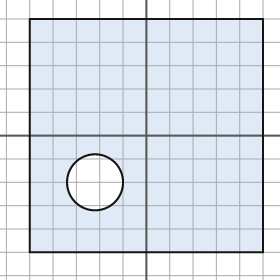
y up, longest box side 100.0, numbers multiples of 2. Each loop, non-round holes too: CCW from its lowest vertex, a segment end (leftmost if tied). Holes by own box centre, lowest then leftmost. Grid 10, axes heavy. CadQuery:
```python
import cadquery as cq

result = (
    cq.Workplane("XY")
    .moveTo(-50.0, -50.0)
    .lineTo(50.0, -50.0)
    .lineTo(50.0, 50.0)
    .lineTo(-50.0, 50.0)
    .close()
    .moveTo(-22.0, -20.0)
    .circle(12.0)
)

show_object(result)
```